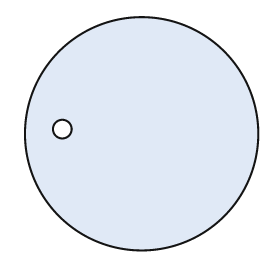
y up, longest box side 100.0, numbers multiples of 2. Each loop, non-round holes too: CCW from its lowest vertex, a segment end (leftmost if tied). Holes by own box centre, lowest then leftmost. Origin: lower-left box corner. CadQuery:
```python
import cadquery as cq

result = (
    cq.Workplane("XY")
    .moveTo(50.0, 50.0)
    .circle(50.0)
    .moveTo(16.0, 52.0)
    .circle(4.0)
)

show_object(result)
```